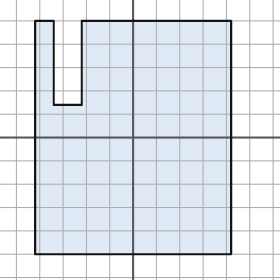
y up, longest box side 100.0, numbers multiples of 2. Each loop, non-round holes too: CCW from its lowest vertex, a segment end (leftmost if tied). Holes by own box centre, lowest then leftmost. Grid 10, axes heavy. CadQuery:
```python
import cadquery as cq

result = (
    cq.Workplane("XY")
    .moveTo(-42.0, -50.0)
    .lineTo(42.0, -50.0)
    .lineTo(42.0, 50.0)
    .lineTo(-22.0, 50.0)
    .lineTo(-22.0, 14.0)
    .lineTo(-34.0, 14.0)
    .lineTo(-34.0, 50.0)
    .lineTo(-42.0, 50.0)
    .close()
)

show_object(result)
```